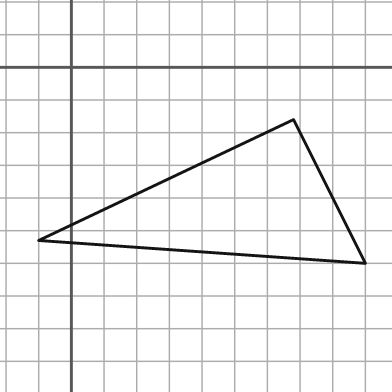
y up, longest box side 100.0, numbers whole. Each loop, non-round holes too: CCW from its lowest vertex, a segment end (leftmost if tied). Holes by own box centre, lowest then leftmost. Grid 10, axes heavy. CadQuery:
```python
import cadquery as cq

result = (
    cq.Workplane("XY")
    .moveTo(90.0, -60.0)
    .lineTo(68.0, -16.0)
    .lineTo(-10.0, -53.0)
    .close()
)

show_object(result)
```